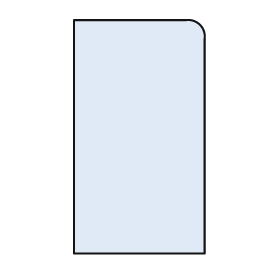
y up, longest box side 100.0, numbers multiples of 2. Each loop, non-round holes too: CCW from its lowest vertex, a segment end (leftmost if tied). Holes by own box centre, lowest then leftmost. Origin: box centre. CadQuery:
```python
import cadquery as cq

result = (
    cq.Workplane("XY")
    .moveTo(-28.0, -50.0)
    .lineTo(28.0, -50.0)
    .lineTo(28.0, 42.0)
    .threePointArc((26.0, 48.0), (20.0, 50.0))
    .lineTo(-28.0, 50.0)
    .close()
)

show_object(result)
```